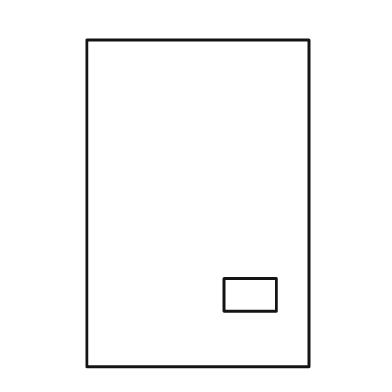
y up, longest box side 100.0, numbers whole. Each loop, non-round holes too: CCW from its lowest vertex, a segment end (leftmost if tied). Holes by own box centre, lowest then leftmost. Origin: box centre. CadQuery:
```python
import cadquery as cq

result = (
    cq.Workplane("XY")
    .moveTo(-34.0, -50.0)
    .lineTo(34.0, -50.0)
    .lineTo(34.0, 50.0)
    .lineTo(-34.0, 50.0)
    .close()
    .moveTo(8.0, -33.0)
    .lineTo(24.0, -33.0)
    .lineTo(24.0, -23.0)
    .lineTo(8.0, -23.0)
    .close()
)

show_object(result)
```